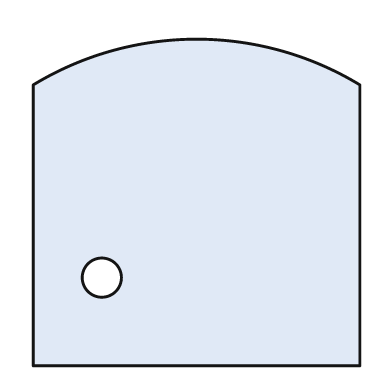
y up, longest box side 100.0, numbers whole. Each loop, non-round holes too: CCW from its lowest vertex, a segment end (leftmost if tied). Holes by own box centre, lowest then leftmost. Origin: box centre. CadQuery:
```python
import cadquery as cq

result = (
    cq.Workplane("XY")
    .moveTo(-50.0, -50.0)
    .lineTo(50.0, -50.0)
    .lineTo(50.0, 36.0)
    .threePointArc((0.0, 50.0), (-50.0, 36.0))
    .close()
    .moveTo(-29.0, -23.0)
    .circle(6.0)
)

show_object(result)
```